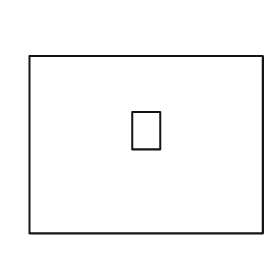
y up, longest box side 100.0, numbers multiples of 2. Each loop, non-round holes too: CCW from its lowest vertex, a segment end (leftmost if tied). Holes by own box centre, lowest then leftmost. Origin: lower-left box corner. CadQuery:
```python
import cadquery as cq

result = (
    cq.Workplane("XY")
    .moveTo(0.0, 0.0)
    .lineTo(100.0, 0.0)
    .lineTo(100.0, 76.0)
    .lineTo(0.0, 76.0)
    .close()
    .moveTo(44.0, 36.0)
    .lineTo(56.0, 36.0)
    .lineTo(56.0, 52.0)
    .lineTo(44.0, 52.0)
    .close()
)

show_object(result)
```